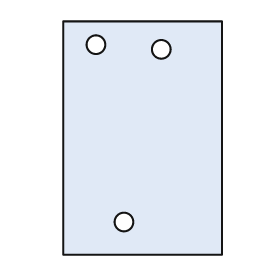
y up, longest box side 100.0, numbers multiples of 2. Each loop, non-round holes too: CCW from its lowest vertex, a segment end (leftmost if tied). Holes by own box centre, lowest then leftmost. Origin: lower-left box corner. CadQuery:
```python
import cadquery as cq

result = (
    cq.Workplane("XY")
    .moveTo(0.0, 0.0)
    .lineTo(68.0, 0.0)
    .lineTo(68.0, 100.0)
    .lineTo(0.0, 100.0)
    .close()
    .moveTo(26.0, 14.0)
    .circle(4.0)
    .moveTo(42.0, 88.0)
    .circle(4.0)
    .moveTo(14.0, 90.0)
    .circle(4.0)
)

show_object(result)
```